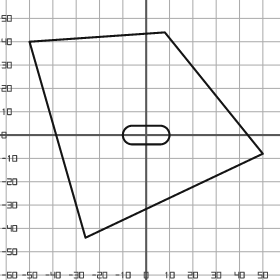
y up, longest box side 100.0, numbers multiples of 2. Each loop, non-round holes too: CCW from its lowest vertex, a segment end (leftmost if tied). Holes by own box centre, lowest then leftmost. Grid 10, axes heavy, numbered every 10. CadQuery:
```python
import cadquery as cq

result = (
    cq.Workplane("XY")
    .moveTo(-26.0, -44.0)
    .lineTo(50.0, -8.0)
    .lineTo(8.0, 44.0)
    .lineTo(-50.0, 40.0)
    .close()
    .moveTo(-6.0, -4.0)
    .lineTo(6.0, -4.0)
    .threePointArc((10.0, 0.0), (6.0, 4.0))
    .lineTo(-6.0, 4.0)
    .threePointArc((-10.0, 0.0), (-6.0, -4.0))
    .close()
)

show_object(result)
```